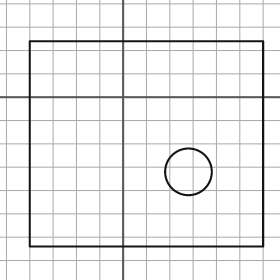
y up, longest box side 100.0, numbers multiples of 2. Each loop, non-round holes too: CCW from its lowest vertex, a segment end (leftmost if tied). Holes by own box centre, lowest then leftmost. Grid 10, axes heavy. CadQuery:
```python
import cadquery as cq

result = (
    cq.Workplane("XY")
    .moveTo(-40.0, -64.0)
    .lineTo(60.0, -64.0)
    .lineTo(60.0, 24.0)
    .lineTo(-40.0, 24.0)
    .close()
    .moveTo(28.0, -32.0)
    .circle(10.0)
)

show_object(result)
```